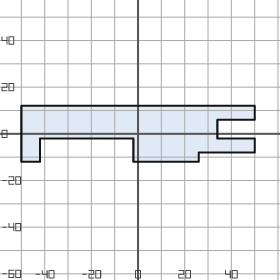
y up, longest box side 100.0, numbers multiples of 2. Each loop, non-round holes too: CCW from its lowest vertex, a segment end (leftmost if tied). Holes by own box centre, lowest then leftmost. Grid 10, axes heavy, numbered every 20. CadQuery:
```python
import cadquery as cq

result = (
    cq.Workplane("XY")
    .moveTo(-50.0, -12.0)
    .lineTo(-42.0, -12.0)
    .lineTo(-42.0, -2.0)
    .lineTo(-2.0, -2.0)
    .lineTo(-2.0, -12.0)
    .lineTo(26.0, -12.0)
    .lineTo(26.0, -8.0)
    .lineTo(50.0, -8.0)
    .lineTo(50.0, -2.0)
    .lineTo(34.0, -2.0)
    .lineTo(34.0, 6.0)
    .lineTo(50.0, 6.0)
    .lineTo(50.0, 12.0)
    .lineTo(-50.0, 12.0)
    .close()
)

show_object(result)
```